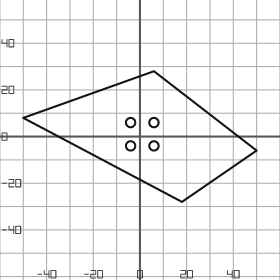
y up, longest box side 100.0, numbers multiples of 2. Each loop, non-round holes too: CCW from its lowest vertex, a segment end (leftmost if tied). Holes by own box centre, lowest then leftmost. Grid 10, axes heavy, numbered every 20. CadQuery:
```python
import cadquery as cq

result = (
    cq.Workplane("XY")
    .moveTo(18.0, -28.0)
    .lineTo(50.0, -6.0)
    .lineTo(6.0, 28.0)
    .lineTo(-50.0, 8.0)
    .close()
    .moveTo(-4.0, -4.0)
    .circle(2.0)
    .moveTo(6.0, -4.0)
    .circle(2.0)
    .moveTo(-4.0, 6.0)
    .circle(2.0)
    .moveTo(6.0, 6.0)
    .circle(2.0)
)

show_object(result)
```